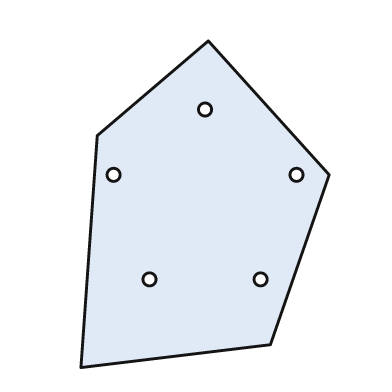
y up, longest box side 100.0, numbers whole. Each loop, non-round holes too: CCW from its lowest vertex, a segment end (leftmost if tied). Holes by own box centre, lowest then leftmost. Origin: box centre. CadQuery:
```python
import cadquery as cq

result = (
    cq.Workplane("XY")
    .moveTo(-38.0, -50.0)
    .lineTo(20.0, -43.0)
    .lineTo(38.0, 9.0)
    .lineTo(1.0, 50.0)
    .lineTo(-33.0, 21.0)
    .close()
    .moveTo(-17.0, -23.0)
    .circle(2.0)
    .moveTo(17.0, -23.0)
    .circle(2.0)
    .moveTo(-28.0, 9.0)
    .circle(2.0)
    .moveTo(28.0, 9.0)
    .circle(2.0)
    .moveTo(0.0, 29.0)
    .circle(2.0)
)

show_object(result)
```